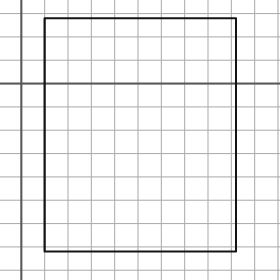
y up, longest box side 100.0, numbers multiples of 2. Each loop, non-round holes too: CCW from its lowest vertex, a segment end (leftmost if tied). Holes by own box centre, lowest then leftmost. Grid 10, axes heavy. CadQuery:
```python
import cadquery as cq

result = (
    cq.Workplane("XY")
    .moveTo(10.0, -72.0)
    .lineTo(92.0, -72.0)
    .lineTo(92.0, 28.0)
    .lineTo(10.0, 28.0)
    .close()
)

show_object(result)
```